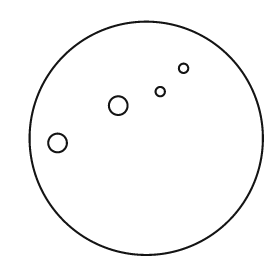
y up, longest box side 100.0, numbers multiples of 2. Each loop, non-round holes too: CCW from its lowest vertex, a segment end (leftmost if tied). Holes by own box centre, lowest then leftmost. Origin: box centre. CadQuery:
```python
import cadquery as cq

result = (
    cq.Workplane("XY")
    .moveTo(0.0, 0.0)
    .circle(50.0)
    .moveTo(-38.0, -2.0)
    .circle(4.0)
    .moveTo(-12.0, 14.0)
    .circle(4.0)
    .moveTo(6.0, 20.0)
    .circle(2.0)
    .moveTo(16.0, 30.0)
    .circle(2.0)
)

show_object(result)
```